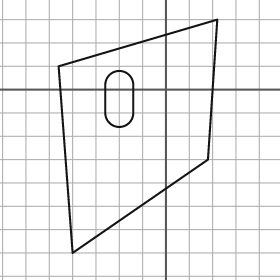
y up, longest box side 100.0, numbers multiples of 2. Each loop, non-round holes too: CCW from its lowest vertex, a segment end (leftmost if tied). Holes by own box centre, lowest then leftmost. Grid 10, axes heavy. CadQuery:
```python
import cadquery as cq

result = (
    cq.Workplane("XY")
    .moveTo(-40.0, -70.0)
    .lineTo(18.0, -30.0)
    .lineTo(22.0, 30.0)
    .lineTo(-46.0, 10.0)
    .close()
    .moveTo(-26.0, -10.0)
    .threePointArc((-20.0, -16.0), (-14.0, -10.0))
    .lineTo(-14.0, 2.0)
    .threePointArc((-20.0, 8.0), (-26.0, 2.0))
    .close()
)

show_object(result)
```